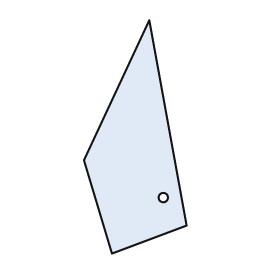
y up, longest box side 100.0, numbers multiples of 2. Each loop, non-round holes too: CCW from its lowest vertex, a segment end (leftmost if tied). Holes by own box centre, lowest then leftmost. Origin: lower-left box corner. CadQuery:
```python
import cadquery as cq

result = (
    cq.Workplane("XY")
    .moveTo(12.0, 0.0)
    .lineTo(44.0, 12.0)
    .lineTo(28.0, 100.0)
    .lineTo(0.0, 40.0)
    .close()
    .moveTo(34.0, 24.0)
    .circle(2.0)
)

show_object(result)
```